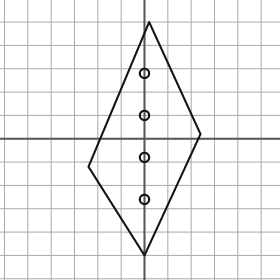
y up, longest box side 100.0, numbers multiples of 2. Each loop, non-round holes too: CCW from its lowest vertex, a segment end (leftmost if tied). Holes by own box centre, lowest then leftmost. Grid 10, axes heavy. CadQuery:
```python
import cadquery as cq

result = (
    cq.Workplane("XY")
    .moveTo(0.0, -50.0)
    .lineTo(24.0, 2.0)
    .lineTo(2.0, 50.0)
    .lineTo(-24.0, -12.0)
    .close()
    .moveTo(0.0, -26.0)
    .circle(2.0)
    .moveTo(0.0, -8.0)
    .circle(2.0)
    .moveTo(0.0, 10.0)
    .circle(2.0)
    .moveTo(0.0, 28.0)
    .circle(2.0)
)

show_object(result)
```